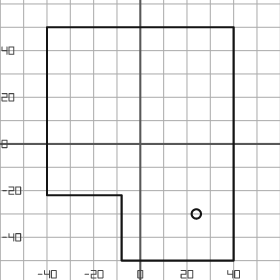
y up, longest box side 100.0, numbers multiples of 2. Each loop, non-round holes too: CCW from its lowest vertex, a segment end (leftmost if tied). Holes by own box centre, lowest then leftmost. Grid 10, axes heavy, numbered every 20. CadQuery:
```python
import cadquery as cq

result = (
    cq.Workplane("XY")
    .moveTo(-8.0, -50.0)
    .lineTo(40.0, -50.0)
    .lineTo(40.0, 50.0)
    .lineTo(-40.0, 50.0)
    .lineTo(-40.0, -22.0)
    .lineTo(-8.0, -22.0)
    .close()
    .moveTo(24.0, -30.0)
    .circle(2.0)
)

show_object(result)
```